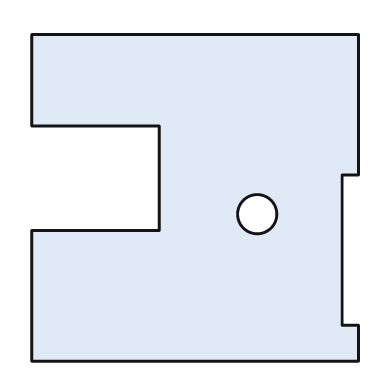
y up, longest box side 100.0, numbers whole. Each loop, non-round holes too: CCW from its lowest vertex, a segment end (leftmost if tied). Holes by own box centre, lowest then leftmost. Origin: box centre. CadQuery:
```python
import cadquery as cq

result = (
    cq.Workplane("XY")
    .moveTo(-50.0, -50.0)
    .lineTo(50.0, -50.0)
    .lineTo(50.0, -39.0)
    .lineTo(45.0, -39.0)
    .lineTo(45.0, 7.0)
    .lineTo(50.0, 7.0)
    .lineTo(50.0, 50.0)
    .lineTo(-50.0, 50.0)
    .lineTo(-50.0, 22.0)
    .lineTo(-11.0, 22.0)
    .lineTo(-11.0, -10.0)
    .lineTo(-50.0, -10.0)
    .close()
    .moveTo(19.0, -5.0)
    .circle(6.0)
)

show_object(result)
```